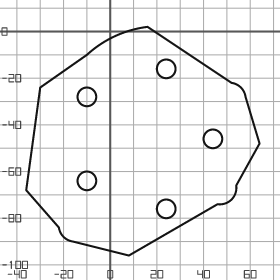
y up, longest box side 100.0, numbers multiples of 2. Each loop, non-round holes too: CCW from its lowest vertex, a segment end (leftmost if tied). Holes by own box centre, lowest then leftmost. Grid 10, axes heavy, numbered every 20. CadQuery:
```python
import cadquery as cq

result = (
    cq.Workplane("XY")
    .moveTo(8.0, -96.0)
    .lineTo(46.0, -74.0)
    .threePointArc((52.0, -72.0), (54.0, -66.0))
    .lineTo(64.0, -48.0)
    .lineTo(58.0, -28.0)
    .threePointArc((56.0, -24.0), (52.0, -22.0))
    .lineTo(16.0, 2.0)
    .threePointArc((2.0, -2.0), (-10.0, -10.0))
    .lineTo(-30.0, -24.0)
    .lineTo(-36.0, -68.0)
    .lineTo(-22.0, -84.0)
    .threePointArc((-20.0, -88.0), (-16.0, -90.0))
    .close()
    .moveTo(24.0, -76.0)
    .circle(4.0)
    .moveTo(-10.0, -64.0)
    .circle(4.0)
    .moveTo(44.0, -46.0)
    .circle(4.0)
    .moveTo(-10.0, -28.0)
    .circle(4.0)
    .moveTo(24.0, -16.0)
    .circle(4.0)
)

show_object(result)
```